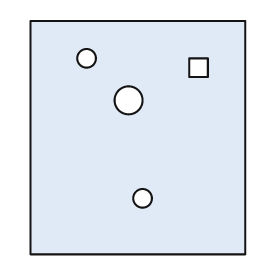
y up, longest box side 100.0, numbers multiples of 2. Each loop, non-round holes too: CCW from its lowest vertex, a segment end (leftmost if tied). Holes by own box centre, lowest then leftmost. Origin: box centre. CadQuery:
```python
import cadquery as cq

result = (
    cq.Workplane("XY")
    .moveTo(-46.0, -50.0)
    .lineTo(46.0, -50.0)
    .lineTo(46.0, 50.0)
    .lineTo(-46.0, 50.0)
    .close()
    .moveTo(2.0, -26.0)
    .circle(4.0)
    .moveTo(-4.0, 16.0)
    .circle(6.0)
    .moveTo(22.0, 26.0)
    .lineTo(30.0, 26.0)
    .lineTo(30.0, 34.0)
    .lineTo(22.0, 34.0)
    .close()
    .moveTo(-22.0, 34.0)
    .circle(4.0)
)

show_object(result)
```